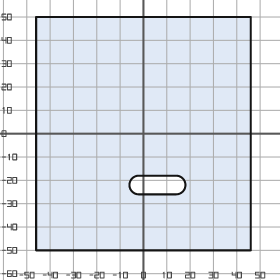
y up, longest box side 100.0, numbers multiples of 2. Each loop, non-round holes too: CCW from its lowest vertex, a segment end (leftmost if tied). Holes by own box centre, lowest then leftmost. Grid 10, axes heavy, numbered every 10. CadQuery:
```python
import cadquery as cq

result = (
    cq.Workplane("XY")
    .moveTo(-46.0, -50.0)
    .lineTo(46.0, -50.0)
    .lineTo(46.0, 50.0)
    .lineTo(-46.0, 50.0)
    .close()
    .moveTo(-2.0, -26.0)
    .lineTo(14.0, -26.0)
    .threePointArc((18.0, -22.0), (14.0, -18.0))
    .lineTo(-2.0, -18.0)
    .threePointArc((-6.0, -22.0), (-2.0, -26.0))
    .close()
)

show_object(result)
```